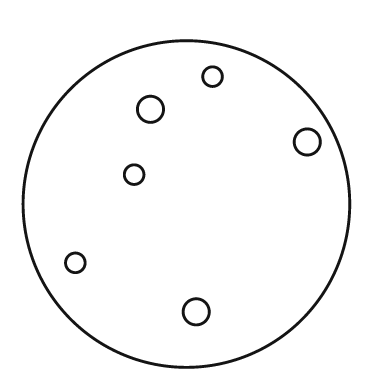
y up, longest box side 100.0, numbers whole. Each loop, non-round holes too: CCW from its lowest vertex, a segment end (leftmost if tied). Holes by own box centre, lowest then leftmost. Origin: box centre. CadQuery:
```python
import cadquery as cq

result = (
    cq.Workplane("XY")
    .moveTo(0.0, 0.0)
    .circle(50.0)
    .moveTo(3.0, -33.0)
    .circle(4.0)
    .moveTo(-34.0, -18.0)
    .circle(3.0)
    .moveTo(-16.0, 9.0)
    .circle(3.0)
    .moveTo(37.0, 19.0)
    .circle(4.0)
    .moveTo(-11.0, 29.0)
    .circle(4.0)
    .moveTo(8.0, 39.0)
    .circle(3.0)
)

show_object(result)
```